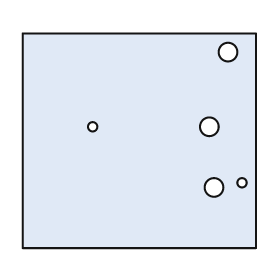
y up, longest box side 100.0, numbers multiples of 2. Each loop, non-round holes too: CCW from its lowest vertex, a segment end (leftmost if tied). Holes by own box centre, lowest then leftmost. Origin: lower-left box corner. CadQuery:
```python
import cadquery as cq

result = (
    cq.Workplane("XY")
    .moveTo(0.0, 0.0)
    .lineTo(100.0, 0.0)
    .lineTo(100.0, 92.0)
    .lineTo(0.0, 92.0)
    .close()
    .moveTo(82.0, 26.0)
    .circle(4.0)
    .moveTo(94.0, 28.0)
    .circle(2.0)
    .moveTo(30.0, 52.0)
    .circle(2.0)
    .moveTo(80.0, 52.0)
    .circle(4.0)
    .moveTo(88.0, 84.0)
    .circle(4.0)
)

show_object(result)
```